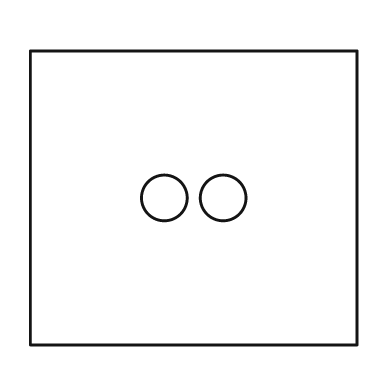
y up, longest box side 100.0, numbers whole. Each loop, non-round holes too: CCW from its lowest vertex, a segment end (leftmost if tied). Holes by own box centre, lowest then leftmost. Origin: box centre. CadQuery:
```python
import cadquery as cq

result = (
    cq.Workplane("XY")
    .moveTo(-50.0, -45.0)
    .lineTo(50.0, -45.0)
    .lineTo(50.0, 45.0)
    .lineTo(-50.0, 45.0)
    .close()
    .moveTo(-9.0, 0.0)
    .circle(7.0)
    .moveTo(9.0, 0.0)
    .circle(7.0)
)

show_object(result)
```